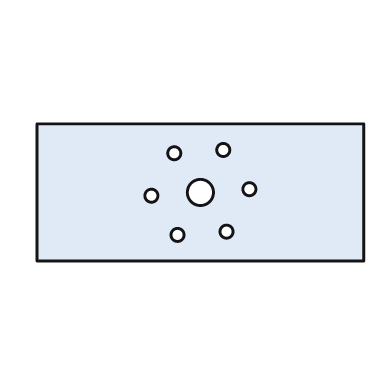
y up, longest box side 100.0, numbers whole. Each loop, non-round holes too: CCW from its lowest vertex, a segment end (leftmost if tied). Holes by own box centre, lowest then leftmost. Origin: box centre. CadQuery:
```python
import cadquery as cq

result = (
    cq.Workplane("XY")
    .moveTo(-50.0, -21.0)
    .lineTo(50.0, -21.0)
    .lineTo(50.0, 21.0)
    .lineTo(-50.0, 21.0)
    .close()
    .moveTo(-7.0, -13.0)
    .circle(2.0)
    .moveTo(8.0, -12.0)
    .circle(2.0)
    .moveTo(-15.0, -1.0)
    .circle(2.0)
    .moveTo(0.0, 0.0)
    .circle(4.0)
    .moveTo(15.0, 1.0)
    .circle(2.0)
    .moveTo(-8.0, 12.0)
    .circle(2.0)
    .moveTo(7.0, 13.0)
    .circle(2.0)
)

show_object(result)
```